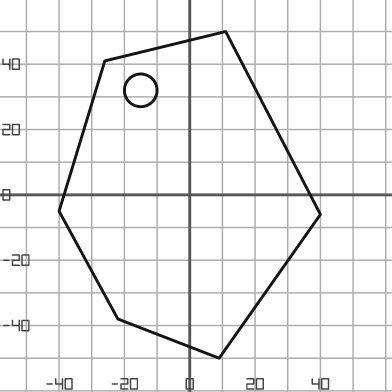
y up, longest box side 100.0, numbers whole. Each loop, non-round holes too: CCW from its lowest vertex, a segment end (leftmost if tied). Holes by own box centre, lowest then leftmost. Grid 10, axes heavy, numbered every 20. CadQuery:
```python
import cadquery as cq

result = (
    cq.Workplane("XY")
    .moveTo(9.0, -50.0)
    .lineTo(40.0, -6.0)
    .lineTo(11.0, 50.0)
    .lineTo(-26.0, 41.0)
    .lineTo(-40.0, -5.0)
    .lineTo(-22.0, -38.0)
    .close()
    .moveTo(-15.0, 32.0)
    .circle(5.0)
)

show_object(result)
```